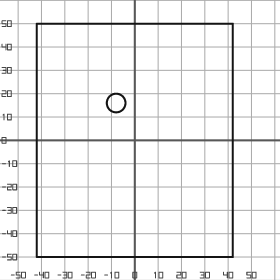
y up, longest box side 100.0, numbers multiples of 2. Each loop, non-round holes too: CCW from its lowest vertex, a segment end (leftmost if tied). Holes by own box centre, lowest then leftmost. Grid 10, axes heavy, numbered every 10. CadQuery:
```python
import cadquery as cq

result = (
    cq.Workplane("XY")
    .moveTo(-42.0, -50.0)
    .lineTo(42.0, -50.0)
    .lineTo(42.0, 50.0)
    .lineTo(-42.0, 50.0)
    .close()
    .moveTo(-8.0, 16.0)
    .circle(4.0)
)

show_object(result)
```